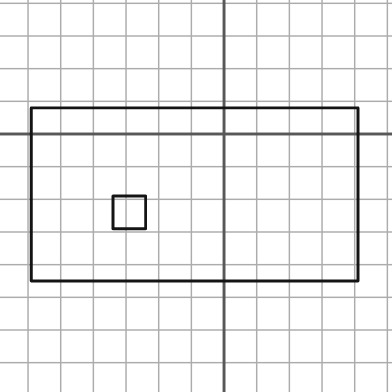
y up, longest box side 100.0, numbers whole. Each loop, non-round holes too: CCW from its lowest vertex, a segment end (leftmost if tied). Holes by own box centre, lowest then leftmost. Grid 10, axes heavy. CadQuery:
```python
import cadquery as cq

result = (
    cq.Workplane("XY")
    .moveTo(-59.0, -45.0)
    .lineTo(41.0, -45.0)
    .lineTo(41.0, 8.0)
    .lineTo(-59.0, 8.0)
    .close()
    .moveTo(-34.0, -29.0)
    .lineTo(-24.0, -29.0)
    .lineTo(-24.0, -19.0)
    .lineTo(-34.0, -19.0)
    .close()
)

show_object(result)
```